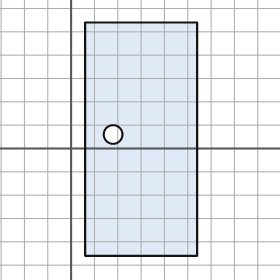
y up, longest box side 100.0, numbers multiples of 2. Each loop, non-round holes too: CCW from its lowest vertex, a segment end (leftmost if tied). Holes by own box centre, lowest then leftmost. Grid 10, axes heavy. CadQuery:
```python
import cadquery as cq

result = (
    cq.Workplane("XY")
    .moveTo(6.0, -46.0)
    .lineTo(54.0, -46.0)
    .lineTo(54.0, 54.0)
    .lineTo(6.0, 54.0)
    .close()
    .moveTo(18.0, 6.0)
    .circle(4.0)
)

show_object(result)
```